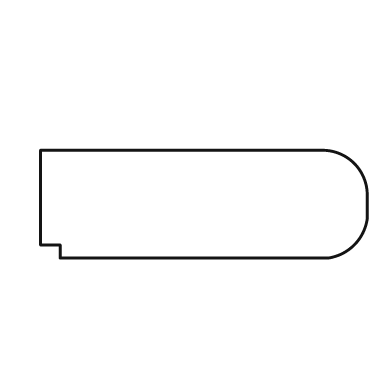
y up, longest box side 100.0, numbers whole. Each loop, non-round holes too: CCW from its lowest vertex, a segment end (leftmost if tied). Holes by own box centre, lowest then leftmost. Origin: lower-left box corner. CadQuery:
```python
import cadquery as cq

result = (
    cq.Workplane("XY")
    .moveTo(6.0, 0.0)
    .lineTo(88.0, 0.0)
    .threePointArc((96.0, 4.0), (100.0, 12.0))
    .lineTo(100.0, 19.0)
    .threePointArc((96.0, 29.0), (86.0, 33.0))
    .lineTo(0.0, 33.0)
    .lineTo(0.0, 4.0)
    .lineTo(6.0, 4.0)
    .close()
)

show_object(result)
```